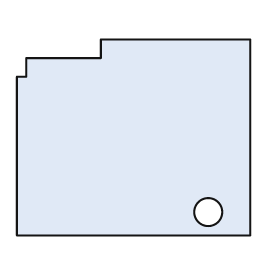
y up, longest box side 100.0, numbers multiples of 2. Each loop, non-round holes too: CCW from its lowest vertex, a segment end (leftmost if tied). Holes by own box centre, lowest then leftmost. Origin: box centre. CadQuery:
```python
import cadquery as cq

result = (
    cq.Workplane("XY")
    .moveTo(-50.0, -42.0)
    .lineTo(50.0, -42.0)
    .lineTo(50.0, 42.0)
    .lineTo(-14.0, 42.0)
    .lineTo(-14.0, 34.0)
    .lineTo(-46.0, 34.0)
    .lineTo(-46.0, 26.0)
    .lineTo(-50.0, 26.0)
    .close()
    .moveTo(32.0, -32.0)
    .circle(6.0)
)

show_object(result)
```